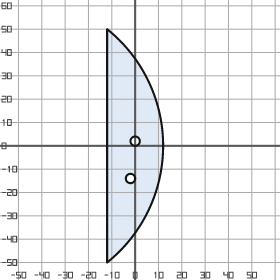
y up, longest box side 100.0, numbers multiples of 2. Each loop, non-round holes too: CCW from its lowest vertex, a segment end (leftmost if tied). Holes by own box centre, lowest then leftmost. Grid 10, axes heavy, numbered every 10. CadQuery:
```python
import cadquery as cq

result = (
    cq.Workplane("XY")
    .moveTo(-12.0, -50.0)
    .threePointArc((12.0, 0.0), (-12.0, 50.0))
    .close()
    .moveTo(-2.0, -14.0)
    .circle(2.0)
    .moveTo(0.0, 2.0)
    .circle(2.0)
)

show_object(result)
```